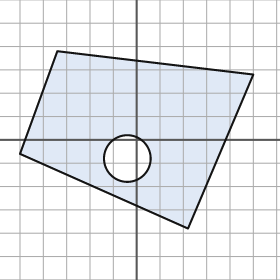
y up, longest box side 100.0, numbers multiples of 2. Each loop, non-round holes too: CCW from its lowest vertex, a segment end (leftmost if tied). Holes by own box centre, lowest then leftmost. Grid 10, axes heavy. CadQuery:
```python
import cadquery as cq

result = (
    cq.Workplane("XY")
    .moveTo(22.0, -38.0)
    .lineTo(50.0, 28.0)
    .lineTo(-34.0, 38.0)
    .lineTo(-50.0, -6.0)
    .close()
    .moveTo(-4.0, -8.0)
    .circle(10.0)
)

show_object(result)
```